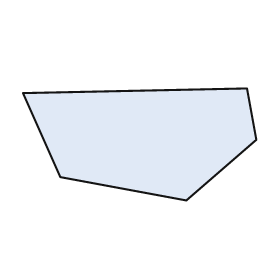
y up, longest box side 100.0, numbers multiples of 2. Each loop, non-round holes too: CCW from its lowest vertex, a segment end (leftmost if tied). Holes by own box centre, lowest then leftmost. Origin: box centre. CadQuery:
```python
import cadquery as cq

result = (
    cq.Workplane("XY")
    .moveTo(20.0, -24.0)
    .lineTo(50.0, 2.0)
    .lineTo(46.0, 24.0)
    .lineTo(-50.0, 22.0)
    .lineTo(-34.0, -14.0)
    .close()
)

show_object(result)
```